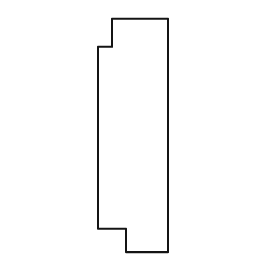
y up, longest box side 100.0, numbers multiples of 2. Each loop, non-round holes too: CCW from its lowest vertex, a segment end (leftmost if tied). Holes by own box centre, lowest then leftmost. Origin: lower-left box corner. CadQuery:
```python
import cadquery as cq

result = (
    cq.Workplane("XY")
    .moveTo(12.0, 0.0)
    .lineTo(30.0, 0.0)
    .lineTo(30.0, 100.0)
    .lineTo(6.0, 100.0)
    .lineTo(6.0, 88.0)
    .lineTo(0.0, 88.0)
    .lineTo(0.0, 10.0)
    .lineTo(12.0, 10.0)
    .close()
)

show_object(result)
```